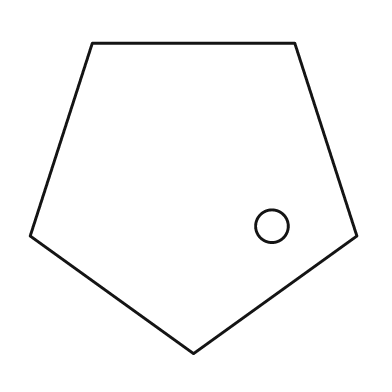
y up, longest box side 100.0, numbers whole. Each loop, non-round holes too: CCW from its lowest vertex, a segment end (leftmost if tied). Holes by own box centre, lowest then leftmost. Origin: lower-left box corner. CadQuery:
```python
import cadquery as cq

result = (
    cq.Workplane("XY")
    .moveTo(50.0, 0.0)
    .lineTo(100.0, 36.0)
    .lineTo(81.0, 95.0)
    .lineTo(19.0, 95.0)
    .lineTo(0.0, 36.0)
    .close()
    .moveTo(74.0, 39.0)
    .circle(5.0)
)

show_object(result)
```